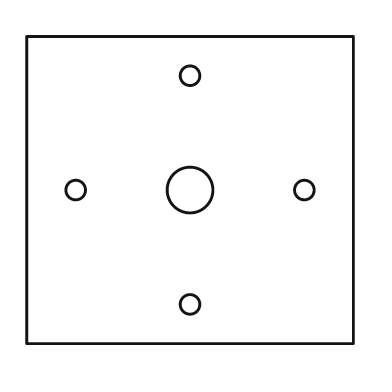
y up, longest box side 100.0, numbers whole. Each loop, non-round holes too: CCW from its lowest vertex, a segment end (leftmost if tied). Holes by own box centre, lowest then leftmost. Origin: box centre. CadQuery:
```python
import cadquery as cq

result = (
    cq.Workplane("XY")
    .moveTo(-50.0, -47.0)
    .lineTo(50.0, -47.0)
    .lineTo(50.0, 47.0)
    .lineTo(-50.0, 47.0)
    .close()
    .moveTo(0.0, -35.0)
    .circle(3.0)
    .moveTo(-35.0, 0.0)
    .circle(3.0)
    .moveTo(0.0, 0.0)
    .circle(7.0)
    .moveTo(35.0, 0.0)
    .circle(3.0)
    .moveTo(0.0, 35.0)
    .circle(3.0)
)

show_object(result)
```